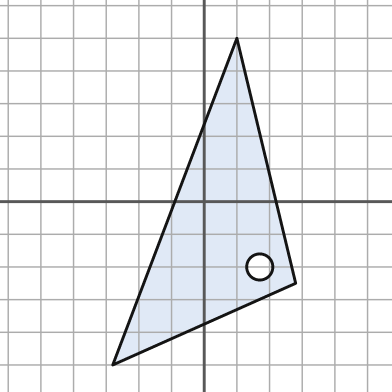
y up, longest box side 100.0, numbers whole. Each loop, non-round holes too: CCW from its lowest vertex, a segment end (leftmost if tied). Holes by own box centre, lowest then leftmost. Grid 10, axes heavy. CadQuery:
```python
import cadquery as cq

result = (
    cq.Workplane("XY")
    .moveTo(-28.0, -50.0)
    .lineTo(28.0, -25.0)
    .lineTo(10.0, 50.0)
    .close()
    .moveTo(17.0, -20.0)
    .circle(4.0)
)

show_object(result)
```